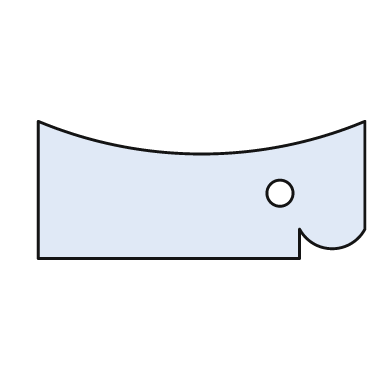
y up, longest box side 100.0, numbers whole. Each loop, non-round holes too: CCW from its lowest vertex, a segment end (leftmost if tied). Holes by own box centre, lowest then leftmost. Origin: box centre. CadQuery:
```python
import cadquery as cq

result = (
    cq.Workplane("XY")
    .moveTo(-50.0, -21.0)
    .lineTo(30.0, -21.0)
    .lineTo(30.0, -12.0)
    .threePointArc((40.0, -18.0), (50.0, -12.0))
    .lineTo(50.0, 21.0)
    .threePointArc((0.0, 11.0), (-50.0, 21.0))
    .close()
    .moveTo(24.0, -1.0)
    .circle(4.0)
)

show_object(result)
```